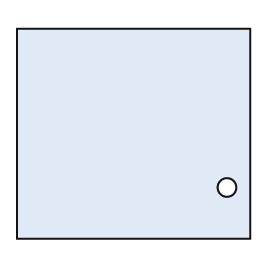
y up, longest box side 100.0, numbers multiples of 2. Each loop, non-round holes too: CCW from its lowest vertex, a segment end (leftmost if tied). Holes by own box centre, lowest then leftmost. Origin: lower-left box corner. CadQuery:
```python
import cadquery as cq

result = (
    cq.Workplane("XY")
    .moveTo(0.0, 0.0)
    .lineTo(100.0, 0.0)
    .lineTo(100.0, 90.0)
    .lineTo(0.0, 90.0)
    .close()
    .moveTo(90.0, 22.0)
    .circle(4.0)
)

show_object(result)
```